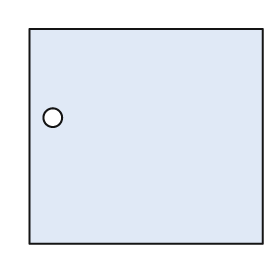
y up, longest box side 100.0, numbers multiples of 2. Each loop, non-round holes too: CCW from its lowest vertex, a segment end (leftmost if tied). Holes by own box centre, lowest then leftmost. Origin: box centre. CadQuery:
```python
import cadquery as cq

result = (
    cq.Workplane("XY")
    .moveTo(-50.0, -46.0)
    .lineTo(50.0, -46.0)
    .lineTo(50.0, 46.0)
    .lineTo(-50.0, 46.0)
    .close()
    .moveTo(-40.0, 8.0)
    .circle(4.0)
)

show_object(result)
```